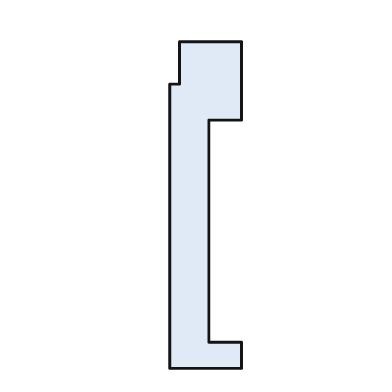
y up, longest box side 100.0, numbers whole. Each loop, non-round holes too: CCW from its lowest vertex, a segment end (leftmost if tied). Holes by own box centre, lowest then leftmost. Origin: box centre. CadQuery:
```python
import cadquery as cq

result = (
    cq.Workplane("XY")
    .moveTo(-11.0, -50.0)
    .lineTo(11.0, -50.0)
    .lineTo(11.0, -42.0)
    .lineTo(1.0, -42.0)
    .lineTo(1.0, 26.0)
    .lineTo(11.0, 26.0)
    .lineTo(11.0, 50.0)
    .lineTo(-8.0, 50.0)
    .lineTo(-8.0, 37.0)
    .lineTo(-11.0, 37.0)
    .close()
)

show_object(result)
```